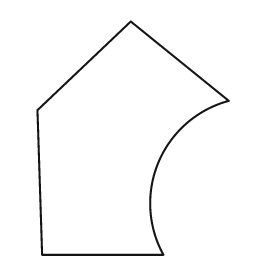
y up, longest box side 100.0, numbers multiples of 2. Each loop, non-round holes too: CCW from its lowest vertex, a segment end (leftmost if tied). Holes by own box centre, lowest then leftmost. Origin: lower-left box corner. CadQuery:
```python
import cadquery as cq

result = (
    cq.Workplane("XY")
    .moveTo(2.0, 0.0)
    .lineTo(54.0, 0.0)
    .threePointArc((52.0, 40.0), (82.0, 66.0))
    .lineTo(40.0, 100.0)
    .lineTo(0.0, 62.0)
    .close()
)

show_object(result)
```